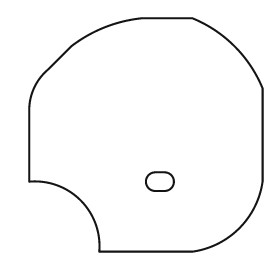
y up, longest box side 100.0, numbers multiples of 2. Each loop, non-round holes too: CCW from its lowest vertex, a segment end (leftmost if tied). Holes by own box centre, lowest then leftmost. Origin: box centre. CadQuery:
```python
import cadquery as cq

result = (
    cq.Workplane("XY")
    .moveTo(-20.0, -50.0)
    .lineTo(20.0, -50.0)
    .threePointArc((40.0, -40.0), (50.0, -20.0))
    .lineTo(50.0, 20.0)
    .threePointArc((38.0, 38.0), (20.0, 50.0))
    .lineTo(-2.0, 50.0)
    .threePointArc((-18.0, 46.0), (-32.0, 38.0))
    .lineTo(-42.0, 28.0)
    .threePointArc((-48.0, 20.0), (-50.0, 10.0))
    .lineTo(-50.0, -20.0)
    .threePointArc((-28.0, -28.0), (-20.0, -50.0))
    .close()
    .moveTo(4.0, -24.0)
    .lineTo(8.0, -24.0)
    .threePointArc((12.0, -20.0), (8.0, -16.0))
    .lineTo(4.0, -16.0)
    .threePointArc((0.0, -20.0), (4.0, -24.0))
    .close()
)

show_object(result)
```